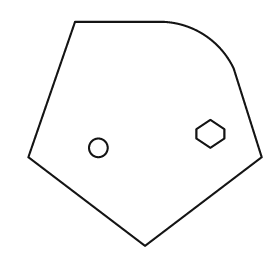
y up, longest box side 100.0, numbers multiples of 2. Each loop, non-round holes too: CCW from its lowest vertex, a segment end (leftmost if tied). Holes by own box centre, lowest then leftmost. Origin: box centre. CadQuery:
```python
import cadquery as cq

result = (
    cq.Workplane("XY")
    .moveTo(0.0, -48.0)
    .lineTo(50.0, -10.0)
    .lineTo(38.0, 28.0)
    .threePointArc((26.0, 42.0), (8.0, 48.0))
    .lineTo(-30.0, 48.0)
    .lineTo(-50.0, -10.0)
    .close()
    .moveTo(-20.0, -6.0)
    .circle(4.0)
    .moveTo(28.0, -6.0)
    .lineTo(34.0, -2.0)
    .lineTo(34.0, 2.0)
    .lineTo(28.0, 6.0)
    .lineTo(22.0, 2.0)
    .lineTo(22.0, -2.0)
    .close()
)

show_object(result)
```